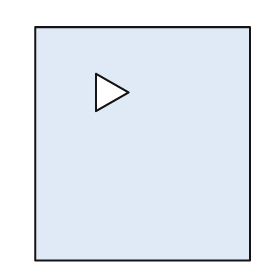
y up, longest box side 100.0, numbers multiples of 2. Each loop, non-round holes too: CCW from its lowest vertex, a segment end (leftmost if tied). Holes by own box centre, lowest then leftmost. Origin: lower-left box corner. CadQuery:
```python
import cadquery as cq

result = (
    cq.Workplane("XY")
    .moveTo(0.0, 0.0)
    .lineTo(92.0, 0.0)
    .lineTo(92.0, 100.0)
    .lineTo(0.0, 100.0)
    .close()
    .moveTo(26.0, 64.0)
    .lineTo(40.0, 72.0)
    .lineTo(26.0, 80.0)
    .close()
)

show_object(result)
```